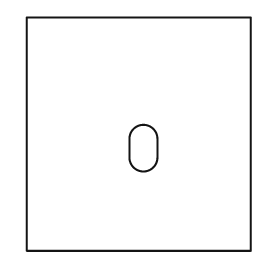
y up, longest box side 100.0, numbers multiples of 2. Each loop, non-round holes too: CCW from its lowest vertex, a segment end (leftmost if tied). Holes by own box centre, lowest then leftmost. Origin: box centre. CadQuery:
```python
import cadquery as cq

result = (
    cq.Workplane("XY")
    .moveTo(-48.0, -50.0)
    .lineTo(48.0, -50.0)
    .lineTo(48.0, 50.0)
    .lineTo(-48.0, 50.0)
    .close()
    .moveTo(-4.0, -10.0)
    .threePointArc((2.0, -16.0), (8.0, -10.0))
    .lineTo(8.0, -2.0)
    .threePointArc((2.0, 4.0), (-4.0, -2.0))
    .close()
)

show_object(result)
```